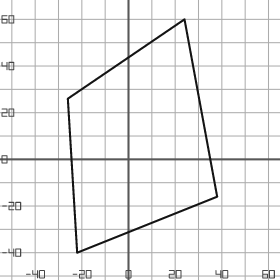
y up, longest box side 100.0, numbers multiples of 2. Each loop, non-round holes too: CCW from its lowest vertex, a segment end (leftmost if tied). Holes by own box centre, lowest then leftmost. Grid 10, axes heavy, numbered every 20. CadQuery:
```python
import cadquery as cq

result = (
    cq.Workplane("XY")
    .moveTo(-22.0, -40.0)
    .lineTo(38.0, -16.0)
    .lineTo(24.0, 60.0)
    .lineTo(-26.0, 26.0)
    .close()
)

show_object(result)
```